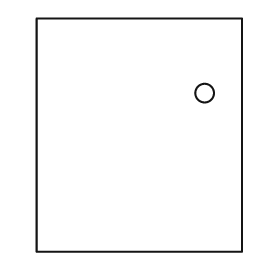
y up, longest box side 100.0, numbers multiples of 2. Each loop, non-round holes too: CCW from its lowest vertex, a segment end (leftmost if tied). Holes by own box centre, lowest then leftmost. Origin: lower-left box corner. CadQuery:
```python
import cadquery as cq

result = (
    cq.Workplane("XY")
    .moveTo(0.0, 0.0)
    .lineTo(88.0, 0.0)
    .lineTo(88.0, 100.0)
    .lineTo(0.0, 100.0)
    .close()
    .moveTo(72.0, 68.0)
    .circle(4.0)
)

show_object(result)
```